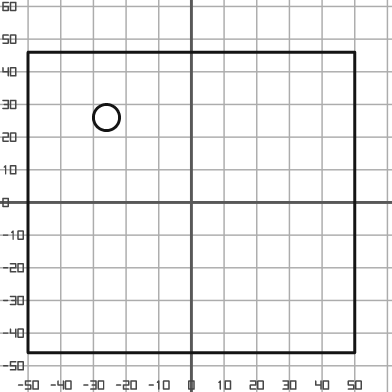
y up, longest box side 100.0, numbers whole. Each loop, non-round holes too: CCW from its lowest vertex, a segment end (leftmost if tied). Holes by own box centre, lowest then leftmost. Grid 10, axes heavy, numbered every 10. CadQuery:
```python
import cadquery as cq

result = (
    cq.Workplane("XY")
    .moveTo(-50.0, -46.0)
    .lineTo(50.0, -46.0)
    .lineTo(50.0, 46.0)
    .lineTo(-50.0, 46.0)
    .close()
    .moveTo(-26.0, 26.0)
    .circle(4.0)
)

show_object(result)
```